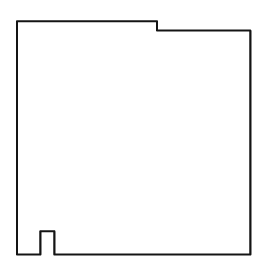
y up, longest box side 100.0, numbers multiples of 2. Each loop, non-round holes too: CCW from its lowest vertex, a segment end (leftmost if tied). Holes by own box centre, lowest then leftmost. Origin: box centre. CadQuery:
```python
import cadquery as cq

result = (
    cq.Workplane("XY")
    .moveTo(-50.0, -50.0)
    .lineTo(-40.0, -50.0)
    .lineTo(-40.0, -40.0)
    .lineTo(-34.0, -40.0)
    .lineTo(-34.0, -50.0)
    .lineTo(50.0, -50.0)
    .lineTo(50.0, 46.0)
    .lineTo(10.0, 46.0)
    .lineTo(10.0, 50.0)
    .lineTo(-50.0, 50.0)
    .close()
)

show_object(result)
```